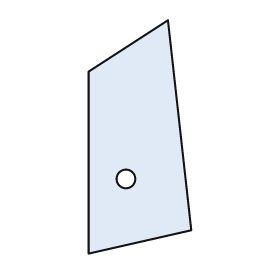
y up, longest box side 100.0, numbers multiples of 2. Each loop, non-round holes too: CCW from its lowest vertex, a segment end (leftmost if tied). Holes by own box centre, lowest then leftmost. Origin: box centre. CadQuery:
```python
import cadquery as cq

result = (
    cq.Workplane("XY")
    .moveTo(-22.0, -50.0)
    .lineTo(22.0, -40.0)
    .lineTo(12.0, 50.0)
    .lineTo(-22.0, 28.0)
    .close()
    .moveTo(-6.0, -18.0)
    .circle(4.0)
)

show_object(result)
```